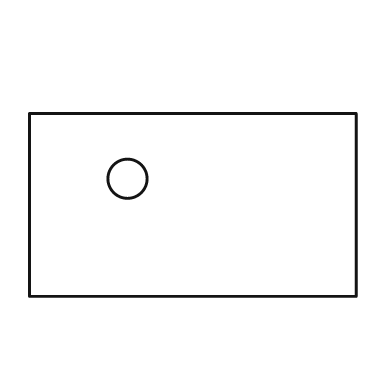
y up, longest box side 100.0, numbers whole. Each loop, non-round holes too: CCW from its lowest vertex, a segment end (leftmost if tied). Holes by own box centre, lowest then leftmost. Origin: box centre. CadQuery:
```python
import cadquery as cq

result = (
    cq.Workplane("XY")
    .moveTo(-50.0, -28.0)
    .lineTo(50.0, -28.0)
    .lineTo(50.0, 28.0)
    .lineTo(-50.0, 28.0)
    .close()
    .moveTo(-20.0, 8.0)
    .circle(6.0)
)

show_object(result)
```